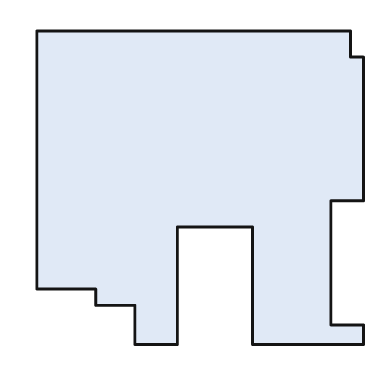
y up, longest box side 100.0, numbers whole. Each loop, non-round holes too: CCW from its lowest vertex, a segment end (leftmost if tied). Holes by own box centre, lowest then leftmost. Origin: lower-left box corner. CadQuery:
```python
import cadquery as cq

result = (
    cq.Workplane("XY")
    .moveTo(30.0, 0.0)
    .lineTo(43.0, 0.0)
    .lineTo(43.0, 36.0)
    .lineTo(66.0, 36.0)
    .lineTo(66.0, 0.0)
    .lineTo(100.0, 0.0)
    .lineTo(100.0, 6.0)
    .lineTo(90.0, 6.0)
    .lineTo(90.0, 44.0)
    .lineTo(100.0, 44.0)
    .lineTo(100.0, 88.0)
    .lineTo(96.0, 88.0)
    .lineTo(96.0, 96.0)
    .lineTo(0.0, 96.0)
    .lineTo(0.0, 17.0)
    .lineTo(18.0, 17.0)
    .lineTo(18.0, 12.0)
    .lineTo(30.0, 12.0)
    .close()
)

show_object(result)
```